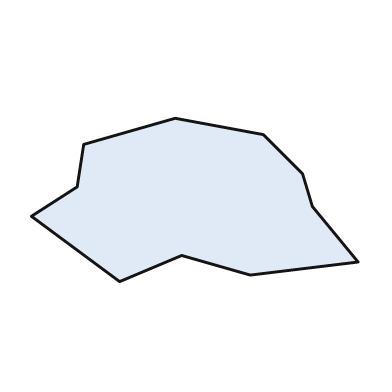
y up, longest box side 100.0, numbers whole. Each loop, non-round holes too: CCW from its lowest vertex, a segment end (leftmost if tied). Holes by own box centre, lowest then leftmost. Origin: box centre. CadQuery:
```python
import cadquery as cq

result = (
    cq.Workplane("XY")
    .moveTo(-23.0, -25.0)
    .lineTo(-4.0, -17.0)
    .lineTo(17.0, -23.0)
    .lineTo(50.0, -19.0)
    .lineTo(36.0, -2.0)
    .lineTo(33.0, 8.0)
    .lineTo(21.0, 20.0)
    .lineTo(-6.0, 25.0)
    .lineTo(-34.0, 17.0)
    .lineTo(-36.0, 4.0)
    .lineTo(-50.0, -5.0)
    .close()
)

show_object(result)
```